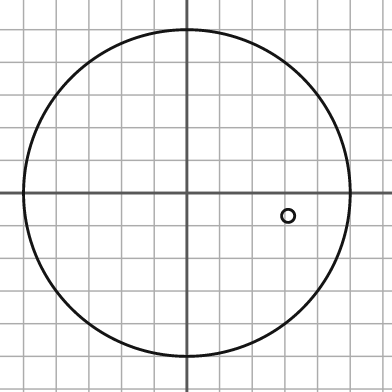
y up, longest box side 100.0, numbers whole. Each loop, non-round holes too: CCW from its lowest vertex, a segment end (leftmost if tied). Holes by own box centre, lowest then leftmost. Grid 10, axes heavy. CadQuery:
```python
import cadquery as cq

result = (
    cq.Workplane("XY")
    .moveTo(0.0, 0.0)
    .circle(50.0)
    .moveTo(31.0, -7.0)
    .circle(2.0)
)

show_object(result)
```